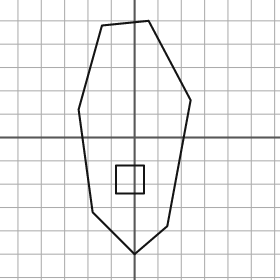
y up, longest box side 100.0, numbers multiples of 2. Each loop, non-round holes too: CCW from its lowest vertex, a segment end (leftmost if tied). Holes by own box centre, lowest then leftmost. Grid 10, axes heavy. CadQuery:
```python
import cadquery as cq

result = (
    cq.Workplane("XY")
    .moveTo(0.0, -50.0)
    .lineTo(14.0, -38.0)
    .lineTo(24.0, 16.0)
    .lineTo(6.0, 50.0)
    .lineTo(-14.0, 48.0)
    .lineTo(-24.0, 12.0)
    .lineTo(-18.0, -32.0)
    .close()
    .moveTo(-8.0, -24.0)
    .lineTo(4.0, -24.0)
    .lineTo(4.0, -12.0)
    .lineTo(-8.0, -12.0)
    .close()
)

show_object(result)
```